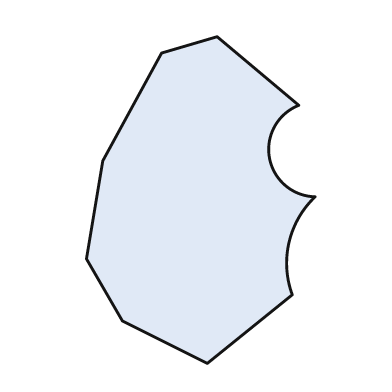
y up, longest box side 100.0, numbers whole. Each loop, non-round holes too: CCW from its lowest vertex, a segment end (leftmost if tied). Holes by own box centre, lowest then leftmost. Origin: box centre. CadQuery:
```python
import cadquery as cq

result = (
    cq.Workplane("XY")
    .moveTo(2.0, -50.0)
    .lineTo(28.0, -29.0)
    .threePointArc((27.0, -13.0), (35.0, 1.0))
    .threePointArc((21.0, 13.0), (30.0, 29.0))
    .lineTo(5.0, 50.0)
    .lineTo(-12.0, 45.0)
    .lineTo(-30.0, 12.0)
    .lineTo(-35.0, -18.0)
    .lineTo(-24.0, -37.0)
    .close()
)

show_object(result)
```